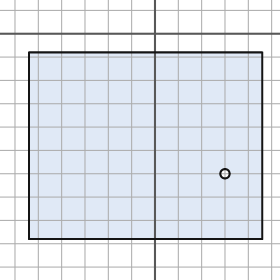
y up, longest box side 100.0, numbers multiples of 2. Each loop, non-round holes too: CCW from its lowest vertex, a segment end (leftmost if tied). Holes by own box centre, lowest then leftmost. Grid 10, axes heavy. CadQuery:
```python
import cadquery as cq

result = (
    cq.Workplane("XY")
    .moveTo(-54.0, -88.0)
    .lineTo(46.0, -88.0)
    .lineTo(46.0, -8.0)
    .lineTo(-54.0, -8.0)
    .close()
    .moveTo(30.0, -60.0)
    .circle(2.0)
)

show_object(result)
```